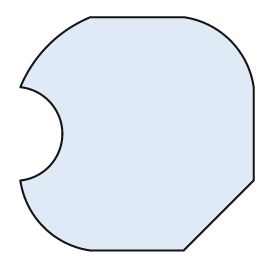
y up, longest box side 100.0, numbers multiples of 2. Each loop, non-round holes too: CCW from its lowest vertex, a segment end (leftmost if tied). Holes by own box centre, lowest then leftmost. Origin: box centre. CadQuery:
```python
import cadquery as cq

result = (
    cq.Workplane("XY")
    .moveTo(-20.0, -50.0)
    .lineTo(20.0, -50.0)
    .lineTo(50.0, -20.0)
    .lineTo(50.0, 20.0)
    .threePointArc((40.0, 40.0), (20.0, 50.0))
    .lineTo(-20.0, 50.0)
    .threePointArc((-38.0, 38.0), (-50.0, 20.0))
    .threePointArc((-32.0, 0.0), (-50.0, -20.0))
    .threePointArc((-40.0, -40.0), (-20.0, -50.0))
    .close()
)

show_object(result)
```